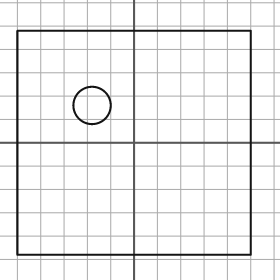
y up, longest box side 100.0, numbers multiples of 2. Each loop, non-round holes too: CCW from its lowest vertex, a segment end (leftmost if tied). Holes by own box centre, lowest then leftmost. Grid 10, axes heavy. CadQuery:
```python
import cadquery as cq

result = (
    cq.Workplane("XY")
    .moveTo(-50.0, -48.0)
    .lineTo(50.0, -48.0)
    .lineTo(50.0, 48.0)
    .lineTo(-50.0, 48.0)
    .close()
    .moveTo(-18.0, 16.0)
    .circle(8.0)
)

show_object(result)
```